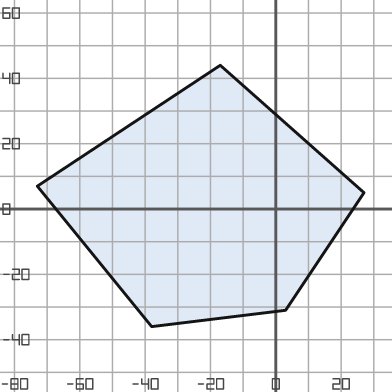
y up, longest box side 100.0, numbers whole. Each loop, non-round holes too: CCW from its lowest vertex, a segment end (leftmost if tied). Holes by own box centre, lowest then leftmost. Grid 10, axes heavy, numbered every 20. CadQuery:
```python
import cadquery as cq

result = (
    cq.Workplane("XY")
    .moveTo(-38.0, -36.0)
    .lineTo(3.0, -31.0)
    .lineTo(27.0, 5.0)
    .lineTo(-17.0, 44.0)
    .lineTo(-73.0, 7.0)
    .close()
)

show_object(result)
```